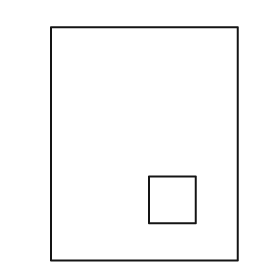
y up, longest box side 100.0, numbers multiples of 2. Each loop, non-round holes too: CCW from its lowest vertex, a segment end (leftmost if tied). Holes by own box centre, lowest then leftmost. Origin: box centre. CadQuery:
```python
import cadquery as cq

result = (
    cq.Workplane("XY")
    .moveTo(-40.0, -50.0)
    .lineTo(40.0, -50.0)
    .lineTo(40.0, 50.0)
    .lineTo(-40.0, 50.0)
    .close()
    .moveTo(2.0, -34.0)
    .lineTo(22.0, -34.0)
    .lineTo(22.0, -14.0)
    .lineTo(2.0, -14.0)
    .close()
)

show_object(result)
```